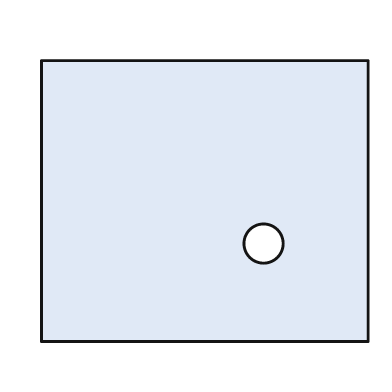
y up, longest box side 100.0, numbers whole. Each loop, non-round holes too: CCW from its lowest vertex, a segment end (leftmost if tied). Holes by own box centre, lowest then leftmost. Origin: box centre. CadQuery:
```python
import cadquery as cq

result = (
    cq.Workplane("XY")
    .moveTo(-50.0, -43.0)
    .lineTo(50.0, -43.0)
    .lineTo(50.0, 43.0)
    .lineTo(-50.0, 43.0)
    .close()
    .moveTo(18.0, -13.0)
    .circle(6.0)
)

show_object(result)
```